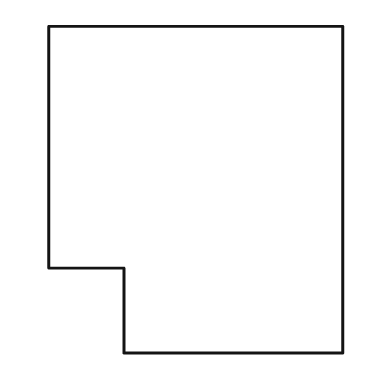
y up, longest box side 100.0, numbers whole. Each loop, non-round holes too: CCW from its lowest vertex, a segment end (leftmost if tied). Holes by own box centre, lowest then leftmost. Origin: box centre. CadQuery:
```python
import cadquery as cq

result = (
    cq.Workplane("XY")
    .moveTo(-22.0, -50.0)
    .lineTo(45.0, -50.0)
    .lineTo(45.0, 50.0)
    .lineTo(-45.0, 50.0)
    .lineTo(-45.0, -24.0)
    .lineTo(-22.0, -24.0)
    .close()
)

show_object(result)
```